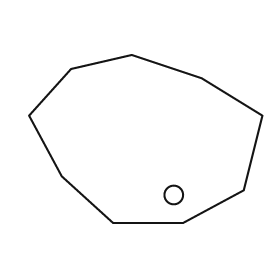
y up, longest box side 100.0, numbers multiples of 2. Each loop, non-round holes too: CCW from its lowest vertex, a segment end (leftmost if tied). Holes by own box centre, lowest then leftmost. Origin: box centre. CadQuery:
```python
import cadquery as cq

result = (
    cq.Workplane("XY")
    .moveTo(-14.0, -36.0)
    .lineTo(16.0, -36.0)
    .lineTo(42.0, -22.0)
    .lineTo(50.0, 10.0)
    .lineTo(24.0, 26.0)
    .lineTo(-6.0, 36.0)
    .lineTo(-32.0, 30.0)
    .lineTo(-50.0, 10.0)
    .lineTo(-36.0, -16.0)
    .close()
    .moveTo(12.0, -24.0)
    .circle(4.0)
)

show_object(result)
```